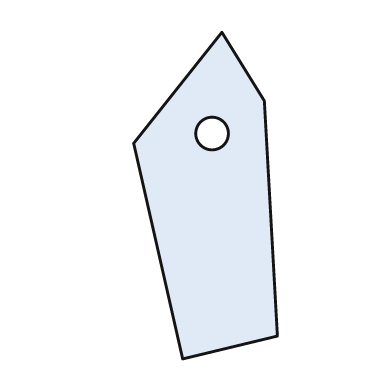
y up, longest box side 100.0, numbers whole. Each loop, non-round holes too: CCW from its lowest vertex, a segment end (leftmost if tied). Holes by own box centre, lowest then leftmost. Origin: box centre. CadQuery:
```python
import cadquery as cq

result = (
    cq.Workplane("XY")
    .moveTo(-7.0, -50.0)
    .lineTo(22.0, -43.0)
    .lineTo(18.0, 29.0)
    .lineTo(5.0, 50.0)
    .lineTo(-22.0, 16.0)
    .close()
    .moveTo(2.0, 19.0)
    .circle(5.0)
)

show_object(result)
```